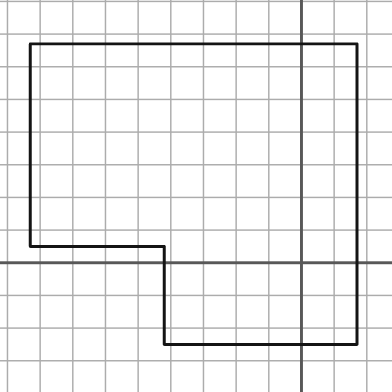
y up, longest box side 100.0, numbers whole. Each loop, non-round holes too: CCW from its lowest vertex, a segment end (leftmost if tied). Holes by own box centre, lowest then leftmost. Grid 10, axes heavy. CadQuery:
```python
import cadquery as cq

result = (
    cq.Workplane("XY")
    .moveTo(-42.0, -25.0)
    .lineTo(17.0, -25.0)
    .lineTo(17.0, 67.0)
    .lineTo(-83.0, 67.0)
    .lineTo(-83.0, 5.0)
    .lineTo(-42.0, 5.0)
    .close()
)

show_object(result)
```